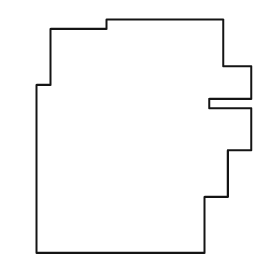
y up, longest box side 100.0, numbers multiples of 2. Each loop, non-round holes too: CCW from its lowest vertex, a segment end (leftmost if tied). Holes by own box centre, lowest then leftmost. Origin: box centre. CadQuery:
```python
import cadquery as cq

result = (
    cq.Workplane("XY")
    .moveTo(-46.0, -50.0)
    .lineTo(26.0, -50.0)
    .lineTo(26.0, -26.0)
    .lineTo(36.0, -26.0)
    .lineTo(36.0, -6.0)
    .lineTo(46.0, -6.0)
    .lineTo(46.0, 12.0)
    .lineTo(28.0, 12.0)
    .lineTo(28.0, 16.0)
    .lineTo(46.0, 16.0)
    .lineTo(46.0, 30.0)
    .lineTo(34.0, 30.0)
    .lineTo(34.0, 50.0)
    .lineTo(-16.0, 50.0)
    .lineTo(-16.0, 46.0)
    .lineTo(-40.0, 46.0)
    .lineTo(-40.0, 22.0)
    .lineTo(-46.0, 22.0)
    .close()
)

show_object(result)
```